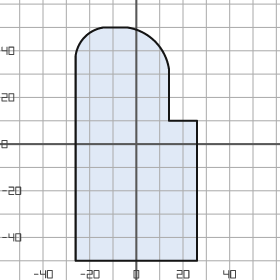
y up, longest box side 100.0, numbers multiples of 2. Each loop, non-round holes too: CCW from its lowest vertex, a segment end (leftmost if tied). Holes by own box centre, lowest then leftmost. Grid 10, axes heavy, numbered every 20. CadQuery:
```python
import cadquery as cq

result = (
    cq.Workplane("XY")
    .moveTo(-26.0, -50.0)
    .lineTo(26.0, -50.0)
    .lineTo(26.0, 10.0)
    .lineTo(14.0, 10.0)
    .lineTo(14.0, 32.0)
    .threePointArc((8.0, 44.0), (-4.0, 50.0))
    .lineTo(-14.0, 50.0)
    .threePointArc((-22.0, 46.0), (-26.0, 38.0))
    .close()
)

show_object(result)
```